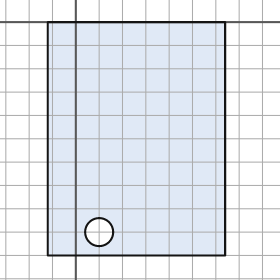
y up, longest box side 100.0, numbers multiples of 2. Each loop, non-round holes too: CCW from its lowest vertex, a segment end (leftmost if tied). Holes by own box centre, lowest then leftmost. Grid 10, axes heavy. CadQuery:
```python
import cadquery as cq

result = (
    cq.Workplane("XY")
    .moveTo(-12.0, -100.0)
    .lineTo(64.0, -100.0)
    .lineTo(64.0, 0.0)
    .lineTo(-12.0, 0.0)
    .close()
    .moveTo(10.0, -90.0)
    .circle(6.0)
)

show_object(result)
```